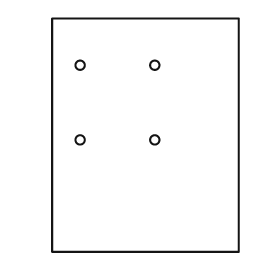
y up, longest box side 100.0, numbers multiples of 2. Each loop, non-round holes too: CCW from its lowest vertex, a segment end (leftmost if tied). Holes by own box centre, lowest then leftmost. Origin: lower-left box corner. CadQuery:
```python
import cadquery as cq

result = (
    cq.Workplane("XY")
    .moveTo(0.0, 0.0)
    .lineTo(80.0, 0.0)
    .lineTo(80.0, 100.0)
    .lineTo(0.0, 100.0)
    .close()
    .moveTo(12.0, 48.0)
    .circle(2.0)
    .moveTo(44.0, 48.0)
    .circle(2.0)
    .moveTo(12.0, 80.0)
    .circle(2.0)
    .moveTo(44.0, 80.0)
    .circle(2.0)
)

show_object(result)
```